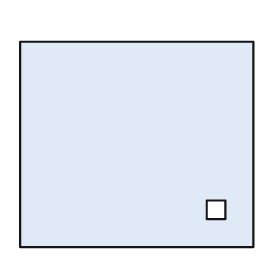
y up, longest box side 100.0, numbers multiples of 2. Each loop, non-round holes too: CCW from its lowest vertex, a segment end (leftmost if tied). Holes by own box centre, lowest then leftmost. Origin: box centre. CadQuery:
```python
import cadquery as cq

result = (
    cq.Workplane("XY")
    .moveTo(-50.0, -44.0)
    .lineTo(50.0, -44.0)
    .lineTo(50.0, 44.0)
    .lineTo(-50.0, 44.0)
    .close()
    .moveTo(30.0, -32.0)
    .lineTo(38.0, -32.0)
    .lineTo(38.0, -24.0)
    .lineTo(30.0, -24.0)
    .close()
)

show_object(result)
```